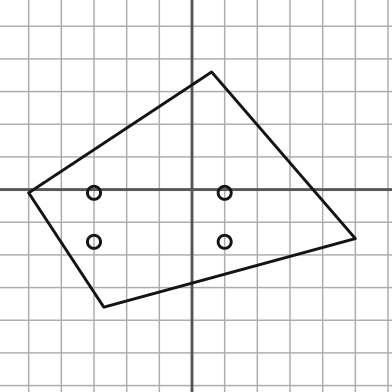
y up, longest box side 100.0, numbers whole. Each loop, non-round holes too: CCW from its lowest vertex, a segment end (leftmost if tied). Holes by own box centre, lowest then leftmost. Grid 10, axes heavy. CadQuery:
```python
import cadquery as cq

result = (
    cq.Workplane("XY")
    .moveTo(-27.0, -36.0)
    .lineTo(50.0, -15.0)
    .lineTo(6.0, 36.0)
    .lineTo(-50.0, -1.0)
    .close()
    .moveTo(-30.0, -16.0)
    .circle(2.0)
    .moveTo(10.0, -16.0)
    .circle(2.0)
    .moveTo(-30.0, -1.0)
    .circle(2.0)
    .moveTo(10.0, -1.0)
    .circle(2.0)
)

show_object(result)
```